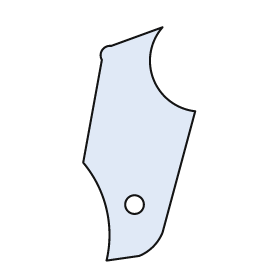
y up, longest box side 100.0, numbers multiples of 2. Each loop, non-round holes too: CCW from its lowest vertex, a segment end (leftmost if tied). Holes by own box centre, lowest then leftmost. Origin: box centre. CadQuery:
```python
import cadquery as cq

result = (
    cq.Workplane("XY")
    .moveTo(-14.0, -50.0)
    .lineTo(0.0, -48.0)
    .threePointArc((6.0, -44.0), (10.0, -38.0))
    .lineTo(24.0, 14.0)
    .threePointArc((6.0, 28.0), (10.0, 50.0))
    .lineTo(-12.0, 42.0)
    .threePointArc((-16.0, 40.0), (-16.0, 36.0))
    .lineTo(-24.0, -8.0)
    .threePointArc((-14.0, -28.0), (-14.0, -50.0))
    .close()
    .moveTo(-2.0, -26.0)
    .circle(4.0)
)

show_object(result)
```